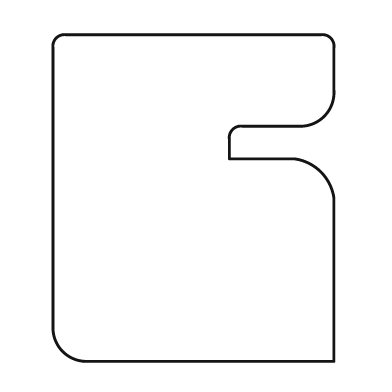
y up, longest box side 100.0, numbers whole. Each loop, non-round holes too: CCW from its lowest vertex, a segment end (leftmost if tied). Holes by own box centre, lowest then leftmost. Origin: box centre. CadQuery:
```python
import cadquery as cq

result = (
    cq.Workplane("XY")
    .moveTo(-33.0, -50.0)
    .lineTo(43.0, -50.0)
    .lineTo(43.0, 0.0)
    .threePointArc((39.0, 8.0), (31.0, 12.0))
    .lineTo(11.0, 12.0)
    .lineTo(11.0, 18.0)
    .threePointArc((12.0, 21.0), (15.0, 22.0))
    .lineTo(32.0, 22.0)
    .threePointArc((40.0, 25.0), (43.0, 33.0))
    .lineTo(43.0, 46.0)
    .threePointArc((42.0, 49.0), (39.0, 50.0))
    .lineTo(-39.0, 50.0)
    .threePointArc((-42.0, 49.0), (-43.0, 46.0))
    .lineTo(-43.0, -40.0)
    .threePointArc((-40.0, -47.0), (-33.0, -50.0))
    .close()
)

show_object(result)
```